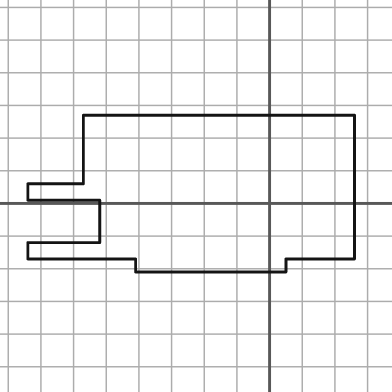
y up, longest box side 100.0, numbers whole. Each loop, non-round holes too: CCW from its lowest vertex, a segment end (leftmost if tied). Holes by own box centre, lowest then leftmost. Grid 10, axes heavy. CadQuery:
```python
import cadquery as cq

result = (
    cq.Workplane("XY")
    .moveTo(-41.0, -21.0)
    .lineTo(5.0, -21.0)
    .lineTo(5.0, -17.0)
    .lineTo(26.0, -17.0)
    .lineTo(26.0, 27.0)
    .lineTo(-57.0, 27.0)
    .lineTo(-57.0, 6.0)
    .lineTo(-74.0, 6.0)
    .lineTo(-74.0, 1.0)
    .lineTo(-52.0, 1.0)
    .lineTo(-52.0, -12.0)
    .lineTo(-74.0, -12.0)
    .lineTo(-74.0, -17.0)
    .lineTo(-41.0, -17.0)
    .close()
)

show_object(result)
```